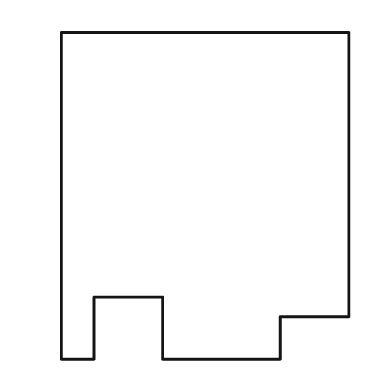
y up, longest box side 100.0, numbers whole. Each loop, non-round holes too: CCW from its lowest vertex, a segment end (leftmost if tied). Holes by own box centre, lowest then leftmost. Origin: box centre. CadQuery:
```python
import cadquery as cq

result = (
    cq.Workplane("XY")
    .moveTo(-44.0, -50.0)
    .lineTo(-34.0, -50.0)
    .lineTo(-34.0, -31.0)
    .lineTo(-13.0, -31.0)
    .lineTo(-13.0, -50.0)
    .lineTo(23.0, -50.0)
    .lineTo(23.0, -37.0)
    .lineTo(44.0, -37.0)
    .lineTo(44.0, 50.0)
    .lineTo(-44.0, 50.0)
    .close()
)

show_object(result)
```